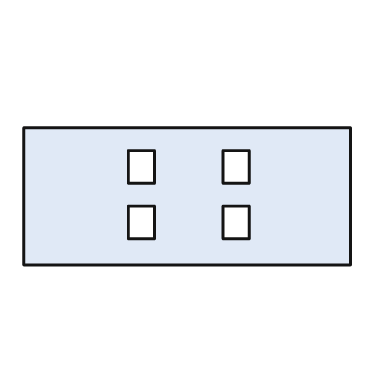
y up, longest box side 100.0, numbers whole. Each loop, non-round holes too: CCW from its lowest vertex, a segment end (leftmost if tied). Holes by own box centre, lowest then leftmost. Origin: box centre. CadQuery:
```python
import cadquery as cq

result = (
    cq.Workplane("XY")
    .moveTo(-50.0, -21.0)
    .lineTo(50.0, -21.0)
    .lineTo(50.0, 21.0)
    .lineTo(-50.0, 21.0)
    .close()
    .moveTo(-18.0, -13.0)
    .lineTo(-10.0, -13.0)
    .lineTo(-10.0, -3.0)
    .lineTo(-18.0, -3.0)
    .close()
    .moveTo(11.0, -13.0)
    .lineTo(19.0, -13.0)
    .lineTo(19.0, -3.0)
    .lineTo(11.0, -3.0)
    .close()
    .moveTo(-18.0, 4.0)
    .lineTo(-10.0, 4.0)
    .lineTo(-10.0, 14.0)
    .lineTo(-18.0, 14.0)
    .close()
    .moveTo(11.0, 4.0)
    .lineTo(19.0, 4.0)
    .lineTo(19.0, 14.0)
    .lineTo(11.0, 14.0)
    .close()
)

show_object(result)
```